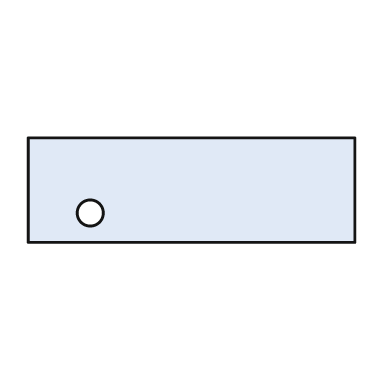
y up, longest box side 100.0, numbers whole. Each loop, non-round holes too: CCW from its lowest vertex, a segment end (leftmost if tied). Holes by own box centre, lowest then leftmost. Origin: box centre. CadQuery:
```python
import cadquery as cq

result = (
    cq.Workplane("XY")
    .moveTo(-50.0, -16.0)
    .lineTo(50.0, -16.0)
    .lineTo(50.0, 16.0)
    .lineTo(-50.0, 16.0)
    .close()
    .moveTo(-31.0, -7.0)
    .circle(4.0)
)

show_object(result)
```